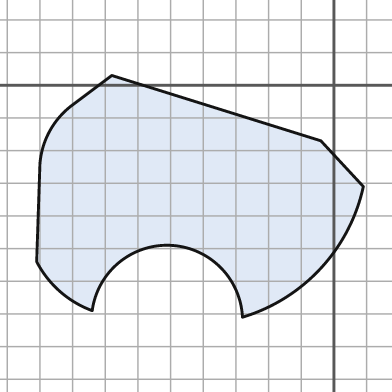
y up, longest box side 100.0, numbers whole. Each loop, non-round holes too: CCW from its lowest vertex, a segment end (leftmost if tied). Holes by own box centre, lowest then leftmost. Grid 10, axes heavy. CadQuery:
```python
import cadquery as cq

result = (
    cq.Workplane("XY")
    .moveTo(-28.0, -71.0)
    .threePointArc((-4.0, -56.0), (9.0, -31.0))
    .lineTo(-4.0, -17.0)
    .lineTo(-68.0, 3.0)
    .lineTo(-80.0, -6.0)
    .threePointArc((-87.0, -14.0), (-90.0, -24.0))
    .lineTo(-91.0, -54.0)
    .threePointArc((-84.0, -63.0), (-74.0, -69.0))
    .threePointArc((-50.0, -49.0), (-28.0, -71.0))
    .close()
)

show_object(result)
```